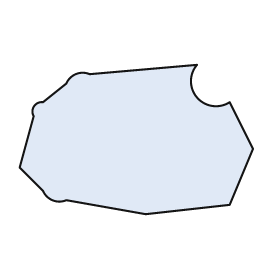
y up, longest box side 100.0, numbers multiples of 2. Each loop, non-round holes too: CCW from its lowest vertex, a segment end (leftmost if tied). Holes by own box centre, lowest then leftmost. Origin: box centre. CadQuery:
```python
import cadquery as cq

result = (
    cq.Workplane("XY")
    .moveTo(4.0, -32.0)
    .lineTo(40.0, -28.0)
    .lineTo(50.0, -4.0)
    .lineTo(40.0, 16.0)
    .threePointArc((26.0, 18.0), (26.0, 32.0))
    .lineTo(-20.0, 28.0)
    .threePointArc((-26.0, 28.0), (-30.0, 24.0))
    .lineTo(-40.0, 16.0)
    .threePointArc((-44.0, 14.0), (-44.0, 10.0))
    .lineTo(-50.0, -12.0)
    .lineTo(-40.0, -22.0)
    .threePointArc((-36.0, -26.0), (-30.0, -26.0))
    .close()
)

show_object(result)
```